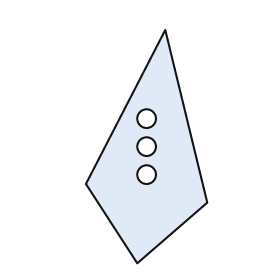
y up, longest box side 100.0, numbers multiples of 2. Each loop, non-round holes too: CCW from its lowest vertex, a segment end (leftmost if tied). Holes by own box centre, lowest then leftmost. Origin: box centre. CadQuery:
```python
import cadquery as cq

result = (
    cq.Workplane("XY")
    .moveTo(-4.0, -50.0)
    .lineTo(26.0, -24.0)
    .lineTo(8.0, 50.0)
    .lineTo(-26.0, -16.0)
    .close()
    .moveTo(0.0, -12.0)
    .circle(4.0)
    .moveTo(0.0, 0.0)
    .circle(4.0)
    .moveTo(0.0, 12.0)
    .circle(4.0)
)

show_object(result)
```